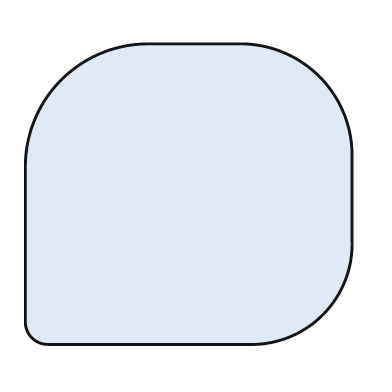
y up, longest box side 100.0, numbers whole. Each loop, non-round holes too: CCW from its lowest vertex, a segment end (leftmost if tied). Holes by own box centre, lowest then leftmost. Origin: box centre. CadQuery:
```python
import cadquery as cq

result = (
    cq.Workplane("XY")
    .moveTo(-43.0, -46.0)
    .lineTo(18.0, -46.0)
    .threePointArc((41.0, -37.0), (50.0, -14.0))
    .lineTo(50.0, 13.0)
    .threePointArc((40.0, 36.0), (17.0, 46.0))
    .lineTo(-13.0, 46.0)
    .threePointArc((-39.0, 35.0), (-50.0, 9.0))
    .lineTo(-50.0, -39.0)
    .threePointArc((-48.0, -44.0), (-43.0, -46.0))
    .close()
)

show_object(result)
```